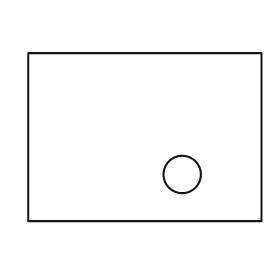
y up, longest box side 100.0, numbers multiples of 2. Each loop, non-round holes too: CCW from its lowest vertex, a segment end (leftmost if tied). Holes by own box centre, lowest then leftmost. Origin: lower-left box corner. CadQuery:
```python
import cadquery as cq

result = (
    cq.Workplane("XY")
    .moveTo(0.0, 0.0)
    .lineTo(100.0, 0.0)
    .lineTo(100.0, 72.0)
    .lineTo(0.0, 72.0)
    .close()
    .moveTo(66.0, 20.0)
    .circle(8.0)
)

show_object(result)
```